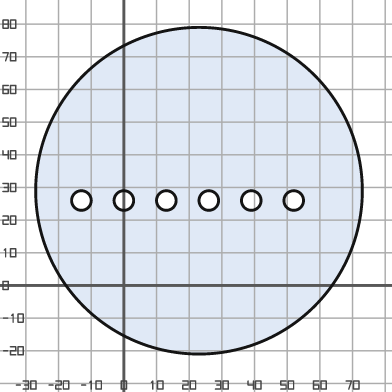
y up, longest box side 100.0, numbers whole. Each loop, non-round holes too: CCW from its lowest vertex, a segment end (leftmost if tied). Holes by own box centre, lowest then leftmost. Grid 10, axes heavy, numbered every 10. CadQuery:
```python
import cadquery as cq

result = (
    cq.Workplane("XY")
    .moveTo(23.0, 29.0)
    .circle(50.0)
    .moveTo(-13.0, 26.0)
    .circle(3.0)
    .moveTo(0.0, 26.0)
    .circle(3.0)
    .moveTo(13.0, 26.0)
    .circle(3.0)
    .moveTo(26.0, 26.0)
    .circle(3.0)
    .moveTo(39.0, 26.0)
    .circle(3.0)
    .moveTo(52.0, 26.0)
    .circle(3.0)
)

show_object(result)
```